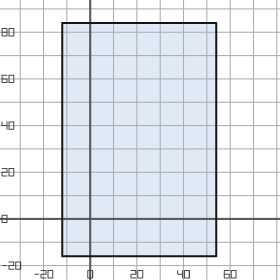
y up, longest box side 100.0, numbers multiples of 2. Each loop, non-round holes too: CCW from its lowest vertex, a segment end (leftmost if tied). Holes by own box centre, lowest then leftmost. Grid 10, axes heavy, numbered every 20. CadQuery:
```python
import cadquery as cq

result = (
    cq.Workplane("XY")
    .moveTo(-12.0, -16.0)
    .lineTo(54.0, -16.0)
    .lineTo(54.0, 84.0)
    .lineTo(-12.0, 84.0)
    .close()
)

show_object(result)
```